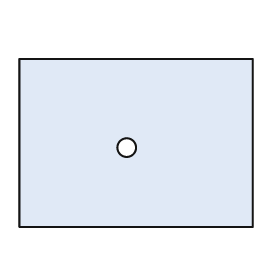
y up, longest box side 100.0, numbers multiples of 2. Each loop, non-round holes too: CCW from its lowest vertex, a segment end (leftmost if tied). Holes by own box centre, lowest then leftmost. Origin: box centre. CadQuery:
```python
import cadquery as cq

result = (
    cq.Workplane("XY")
    .moveTo(-50.0, -36.0)
    .lineTo(50.0, -36.0)
    .lineTo(50.0, 36.0)
    .lineTo(-50.0, 36.0)
    .close()
    .moveTo(-4.0, -2.0)
    .circle(4.0)
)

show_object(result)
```